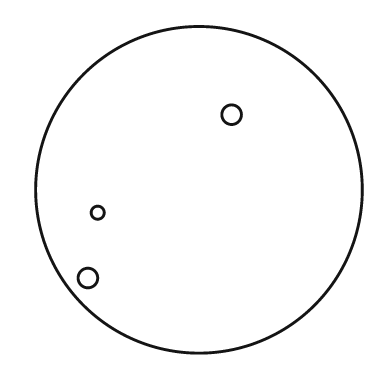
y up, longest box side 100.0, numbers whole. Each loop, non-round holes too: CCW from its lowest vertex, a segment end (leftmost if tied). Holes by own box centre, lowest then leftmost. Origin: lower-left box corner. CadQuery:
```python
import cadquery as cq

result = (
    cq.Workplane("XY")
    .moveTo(50.0, 50.0)
    .circle(50.0)
    .moveTo(16.0, 23.0)
    .circle(3.0)
    .moveTo(19.0, 43.0)
    .circle(2.0)
    .moveTo(60.0, 73.0)
    .circle(3.0)
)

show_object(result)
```